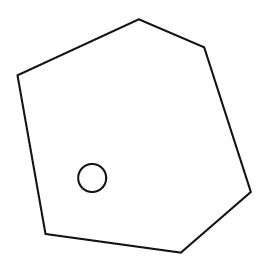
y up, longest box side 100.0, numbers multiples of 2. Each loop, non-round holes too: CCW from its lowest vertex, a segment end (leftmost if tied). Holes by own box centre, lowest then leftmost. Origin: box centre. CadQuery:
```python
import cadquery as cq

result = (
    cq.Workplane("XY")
    .moveTo(20.0, -50.0)
    .lineTo(50.0, -24.0)
    .lineTo(30.0, 38.0)
    .lineTo(2.0, 50.0)
    .lineTo(-50.0, 26.0)
    .lineTo(-38.0, -42.0)
    .close()
    .moveTo(-18.0, -18.0)
    .circle(6.0)
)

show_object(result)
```